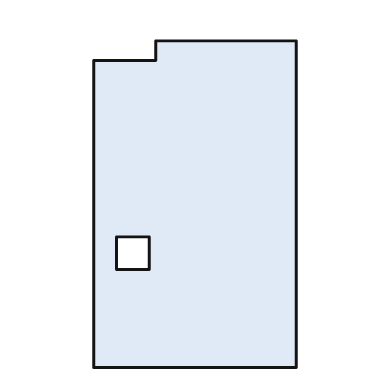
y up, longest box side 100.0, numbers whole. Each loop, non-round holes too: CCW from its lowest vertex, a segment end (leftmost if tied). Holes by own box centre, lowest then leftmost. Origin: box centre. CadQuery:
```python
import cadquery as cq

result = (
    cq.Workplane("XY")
    .moveTo(-31.0, -50.0)
    .lineTo(31.0, -50.0)
    .lineTo(31.0, 50.0)
    .lineTo(-12.0, 50.0)
    .lineTo(-12.0, 44.0)
    .lineTo(-31.0, 44.0)
    .close()
    .moveTo(-24.0, -20.0)
    .lineTo(-14.0, -20.0)
    .lineTo(-14.0, -10.0)
    .lineTo(-24.0, -10.0)
    .close()
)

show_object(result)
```